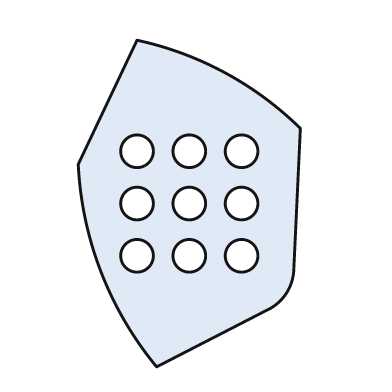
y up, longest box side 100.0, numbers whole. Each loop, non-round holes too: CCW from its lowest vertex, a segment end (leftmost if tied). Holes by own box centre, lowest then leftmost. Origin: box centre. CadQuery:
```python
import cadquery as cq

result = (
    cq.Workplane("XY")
    .moveTo(-10.0, -50.0)
    .lineTo(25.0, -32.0)
    .threePointArc((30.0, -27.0), (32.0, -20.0))
    .lineTo(34.0, 23.0)
    .threePointArc((11.0, 40.0), (-16.0, 50.0))
    .lineTo(-34.0, 12.0)
    .threePointArc((-27.0, -21.0), (-10.0, -50.0))
    .close()
    .moveTo(-16.0, -16.0)
    .circle(5.0)
    .moveTo(0.0, -16.0)
    .circle(5.0)
    .moveTo(16.0, -16.0)
    .circle(5.0)
    .moveTo(-16.0, 0.0)
    .circle(5.0)
    .moveTo(0.0, 0.0)
    .circle(5.0)
    .moveTo(16.0, 0.0)
    .circle(5.0)
    .moveTo(-16.0, 16.0)
    .circle(5.0)
    .moveTo(0.0, 16.0)
    .circle(5.0)
    .moveTo(16.0, 16.0)
    .circle(5.0)
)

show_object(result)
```